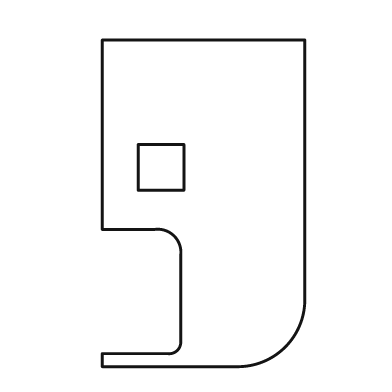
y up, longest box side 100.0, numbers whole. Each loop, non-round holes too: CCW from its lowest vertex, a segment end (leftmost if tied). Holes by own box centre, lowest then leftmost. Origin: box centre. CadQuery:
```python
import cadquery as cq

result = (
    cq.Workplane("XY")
    .moveTo(-31.0, -50.0)
    .lineTo(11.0, -50.0)
    .threePointArc((25.0, -44.0), (31.0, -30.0))
    .lineTo(31.0, 50.0)
    .lineTo(-31.0, 50.0)
    .lineTo(-31.0, -8.0)
    .lineTo(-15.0, -8.0)
    .threePointArc((-9.0, -10.0), (-7.0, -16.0))
    .lineTo(-7.0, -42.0)
    .threePointArc((-8.0, -45.0), (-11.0, -46.0))
    .lineTo(-31.0, -46.0)
    .close()
    .moveTo(-20.0, 4.0)
    .lineTo(-6.0, 4.0)
    .lineTo(-6.0, 18.0)
    .lineTo(-20.0, 18.0)
    .close()
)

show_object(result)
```